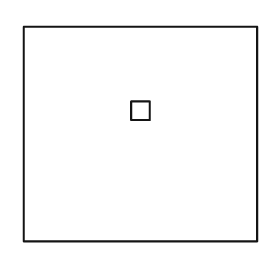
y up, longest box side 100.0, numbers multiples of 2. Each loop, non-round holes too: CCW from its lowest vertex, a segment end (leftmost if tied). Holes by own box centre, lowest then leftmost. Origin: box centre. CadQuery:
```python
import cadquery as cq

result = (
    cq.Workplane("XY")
    .moveTo(-50.0, -46.0)
    .lineTo(50.0, -46.0)
    .lineTo(50.0, 46.0)
    .lineTo(-50.0, 46.0)
    .close()
    .moveTo(-4.0, 6.0)
    .lineTo(4.0, 6.0)
    .lineTo(4.0, 14.0)
    .lineTo(-4.0, 14.0)
    .close()
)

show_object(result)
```